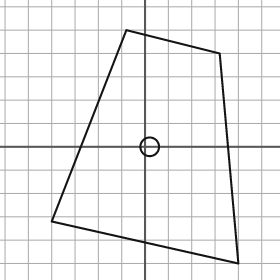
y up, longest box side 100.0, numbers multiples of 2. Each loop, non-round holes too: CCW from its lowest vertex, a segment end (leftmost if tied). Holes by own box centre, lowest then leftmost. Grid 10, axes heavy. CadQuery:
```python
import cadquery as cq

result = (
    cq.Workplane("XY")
    .moveTo(40.0, -50.0)
    .lineTo(32.0, 40.0)
    .lineTo(-8.0, 50.0)
    .lineTo(-40.0, -32.0)
    .close()
    .moveTo(2.0, 0.0)
    .circle(4.0)
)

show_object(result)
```